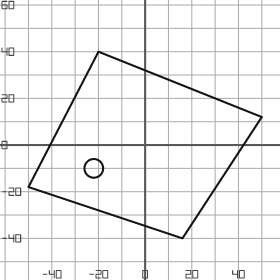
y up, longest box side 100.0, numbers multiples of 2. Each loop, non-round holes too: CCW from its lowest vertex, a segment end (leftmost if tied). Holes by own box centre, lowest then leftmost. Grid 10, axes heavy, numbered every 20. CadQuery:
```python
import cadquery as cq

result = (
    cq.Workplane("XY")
    .moveTo(16.0, -40.0)
    .lineTo(50.0, 12.0)
    .lineTo(-20.0, 40.0)
    .lineTo(-50.0, -18.0)
    .close()
    .moveTo(-22.0, -10.0)
    .circle(4.0)
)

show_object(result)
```